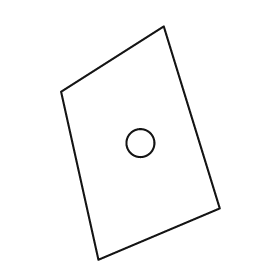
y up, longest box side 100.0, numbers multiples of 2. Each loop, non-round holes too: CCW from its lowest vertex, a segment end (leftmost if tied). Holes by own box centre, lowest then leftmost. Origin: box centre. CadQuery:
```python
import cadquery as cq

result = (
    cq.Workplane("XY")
    .moveTo(-18.0, -50.0)
    .lineTo(34.0, -28.0)
    .lineTo(10.0, 50.0)
    .lineTo(-34.0, 22.0)
    .close()
    .moveTo(0.0, 0.0)
    .circle(6.0)
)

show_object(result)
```